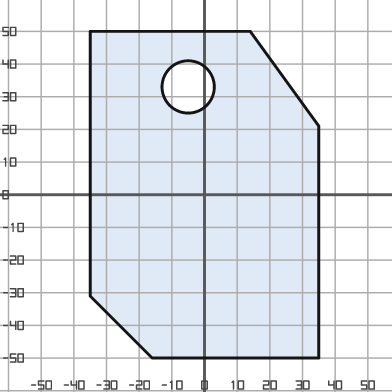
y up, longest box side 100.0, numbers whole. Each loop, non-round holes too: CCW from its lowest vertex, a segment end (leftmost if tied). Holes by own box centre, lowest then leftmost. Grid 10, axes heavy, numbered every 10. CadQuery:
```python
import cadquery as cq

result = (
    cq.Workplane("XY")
    .moveTo(-16.0, -50.0)
    .lineTo(35.0, -50.0)
    .lineTo(35.0, 21.0)
    .lineTo(14.0, 50.0)
    .lineTo(-35.0, 50.0)
    .lineTo(-35.0, -31.0)
    .close()
    .moveTo(-5.0, 33.0)
    .circle(8.0)
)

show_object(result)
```